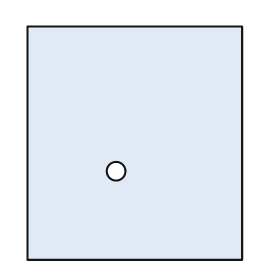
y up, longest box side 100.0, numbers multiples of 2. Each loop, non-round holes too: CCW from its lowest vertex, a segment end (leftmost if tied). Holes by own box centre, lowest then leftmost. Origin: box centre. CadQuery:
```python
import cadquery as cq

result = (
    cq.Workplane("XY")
    .moveTo(-46.0, -50.0)
    .lineTo(46.0, -50.0)
    .lineTo(46.0, 50.0)
    .lineTo(-46.0, 50.0)
    .close()
    .moveTo(-8.0, -12.0)
    .circle(4.0)
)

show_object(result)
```